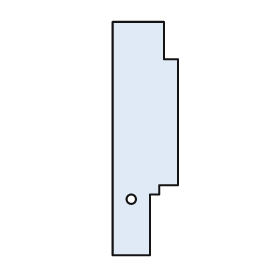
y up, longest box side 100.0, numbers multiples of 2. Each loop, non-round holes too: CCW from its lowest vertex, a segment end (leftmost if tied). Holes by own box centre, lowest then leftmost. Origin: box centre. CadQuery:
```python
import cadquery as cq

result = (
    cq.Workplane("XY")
    .moveTo(-14.0, -50.0)
    .lineTo(2.0, -50.0)
    .lineTo(2.0, -24.0)
    .lineTo(6.0, -24.0)
    .lineTo(6.0, -20.0)
    .lineTo(14.0, -20.0)
    .lineTo(14.0, 34.0)
    .lineTo(8.0, 34.0)
    .lineTo(8.0, 50.0)
    .lineTo(-14.0, 50.0)
    .close()
    .moveTo(-6.0, -26.0)
    .circle(2.0)
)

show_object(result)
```